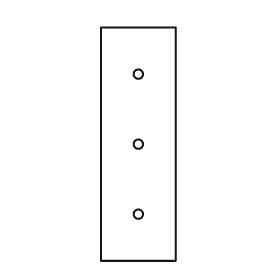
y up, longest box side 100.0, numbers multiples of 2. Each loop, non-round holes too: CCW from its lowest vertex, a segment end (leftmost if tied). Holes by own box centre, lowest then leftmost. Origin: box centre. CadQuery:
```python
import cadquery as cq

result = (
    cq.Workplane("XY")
    .moveTo(-16.0, -50.0)
    .lineTo(16.0, -50.0)
    .lineTo(16.0, 50.0)
    .lineTo(-16.0, 50.0)
    .close()
    .moveTo(0.0, -30.0)
    .circle(2.0)
    .moveTo(0.0, 0.0)
    .circle(2.0)
    .moveTo(0.0, 30.0)
    .circle(2.0)
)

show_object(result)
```